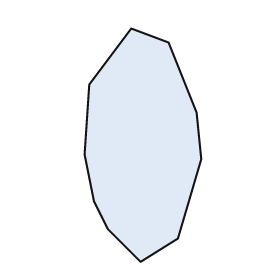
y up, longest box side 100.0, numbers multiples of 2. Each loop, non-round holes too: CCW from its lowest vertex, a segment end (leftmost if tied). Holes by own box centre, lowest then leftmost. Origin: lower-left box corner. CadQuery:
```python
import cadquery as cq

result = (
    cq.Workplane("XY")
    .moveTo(24.0, 0.0)
    .lineTo(40.0, 10.0)
    .lineTo(50.0, 44.0)
    .lineTo(48.0, 64.0)
    .lineTo(36.0, 94.0)
    .lineTo(20.0, 100.0)
    .lineTo(2.0, 76.0)
    .lineTo(0.0, 46.0)
    .lineTo(4.0, 26.0)
    .lineTo(10.0, 14.0)
    .close()
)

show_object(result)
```